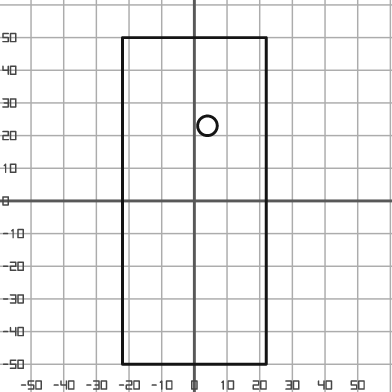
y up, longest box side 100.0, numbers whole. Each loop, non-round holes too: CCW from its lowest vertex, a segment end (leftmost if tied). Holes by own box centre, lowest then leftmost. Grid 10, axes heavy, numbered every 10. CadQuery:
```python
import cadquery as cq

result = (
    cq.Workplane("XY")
    .moveTo(-22.0, -50.0)
    .lineTo(22.0, -50.0)
    .lineTo(22.0, 50.0)
    .lineTo(-22.0, 50.0)
    .close()
    .moveTo(4.0, 23.0)
    .circle(3.0)
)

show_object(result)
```